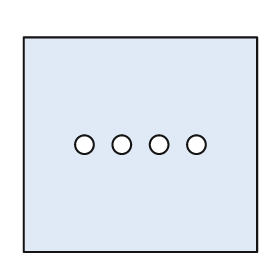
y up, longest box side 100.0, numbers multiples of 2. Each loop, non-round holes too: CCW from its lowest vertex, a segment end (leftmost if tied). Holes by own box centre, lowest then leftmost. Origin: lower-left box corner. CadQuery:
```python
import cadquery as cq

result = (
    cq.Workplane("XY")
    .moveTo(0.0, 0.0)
    .lineTo(100.0, 0.0)
    .lineTo(100.0, 92.0)
    .lineTo(0.0, 92.0)
    .close()
    .moveTo(26.0, 46.0)
    .circle(4.0)
    .moveTo(42.0, 46.0)
    .circle(4.0)
    .moveTo(58.0, 46.0)
    .circle(4.0)
    .moveTo(74.0, 46.0)
    .circle(4.0)
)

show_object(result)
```